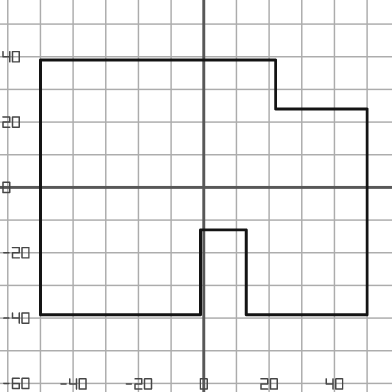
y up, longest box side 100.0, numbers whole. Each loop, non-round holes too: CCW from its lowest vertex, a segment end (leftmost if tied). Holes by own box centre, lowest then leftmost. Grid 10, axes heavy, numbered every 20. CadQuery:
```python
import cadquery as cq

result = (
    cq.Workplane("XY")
    .moveTo(-50.0, -39.0)
    .lineTo(-1.0, -39.0)
    .lineTo(-1.0, -13.0)
    .lineTo(13.0, -13.0)
    .lineTo(13.0, -39.0)
    .lineTo(50.0, -39.0)
    .lineTo(50.0, 24.0)
    .lineTo(22.0, 24.0)
    .lineTo(22.0, 39.0)
    .lineTo(-50.0, 39.0)
    .close()
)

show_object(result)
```